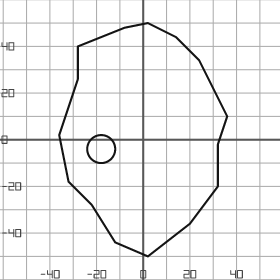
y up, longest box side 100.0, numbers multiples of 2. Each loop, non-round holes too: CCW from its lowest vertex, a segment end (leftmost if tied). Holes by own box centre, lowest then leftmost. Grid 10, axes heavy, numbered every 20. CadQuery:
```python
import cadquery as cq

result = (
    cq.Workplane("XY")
    .moveTo(2.0, -50.0)
    .lineTo(20.0, -36.0)
    .lineTo(32.0, -20.0)
    .lineTo(32.0, -2.0)
    .lineTo(36.0, 10.0)
    .lineTo(24.0, 34.0)
    .lineTo(14.0, 44.0)
    .lineTo(2.0, 50.0)
    .lineTo(-8.0, 48.0)
    .lineTo(-28.0, 40.0)
    .lineTo(-28.0, 26.0)
    .lineTo(-36.0, 2.0)
    .lineTo(-32.0, -18.0)
    .lineTo(-22.0, -28.0)
    .lineTo(-12.0, -44.0)
    .close()
    .moveTo(-18.0, -4.0)
    .circle(6.0)
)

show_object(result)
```